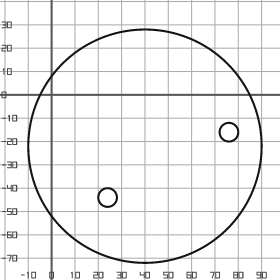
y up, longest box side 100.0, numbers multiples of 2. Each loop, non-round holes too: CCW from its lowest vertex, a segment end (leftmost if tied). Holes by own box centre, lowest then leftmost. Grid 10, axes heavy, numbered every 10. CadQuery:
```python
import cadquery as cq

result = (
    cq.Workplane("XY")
    .moveTo(40.0, -22.0)
    .circle(50.0)
    .moveTo(24.0, -44.0)
    .circle(4.0)
    .moveTo(76.0, -16.0)
    .circle(4.0)
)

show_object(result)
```